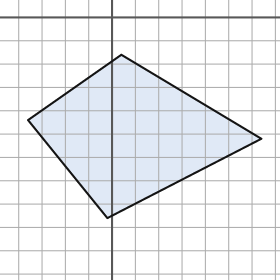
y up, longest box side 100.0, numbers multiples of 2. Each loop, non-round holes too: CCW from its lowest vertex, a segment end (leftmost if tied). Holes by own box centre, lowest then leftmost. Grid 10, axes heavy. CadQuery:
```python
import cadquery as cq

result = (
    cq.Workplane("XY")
    .moveTo(-2.0, -86.0)
    .lineTo(64.0, -52.0)
    .lineTo(4.0, -16.0)
    .lineTo(-36.0, -44.0)
    .close()
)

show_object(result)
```